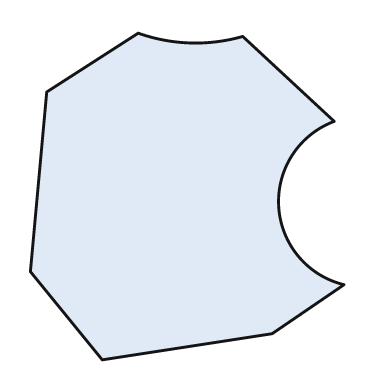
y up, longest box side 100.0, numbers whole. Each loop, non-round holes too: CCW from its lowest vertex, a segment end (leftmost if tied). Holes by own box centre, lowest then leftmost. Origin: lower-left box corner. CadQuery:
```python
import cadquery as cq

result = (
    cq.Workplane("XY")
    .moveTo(22.0, 0.0)
    .lineTo(74.0, 8.0)
    .lineTo(96.0, 23.0)
    .threePointArc((76.0, 47.0), (93.0, 73.0))
    .lineTo(65.0, 99.0)
    .threePointArc((49.0, 97.0), (33.0, 100.0))
    .lineTo(5.0, 82.0)
    .lineTo(0.0, 27.0)
    .close()
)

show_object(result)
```